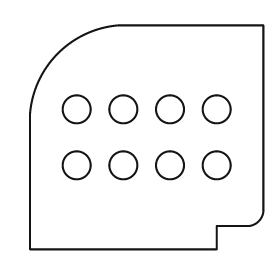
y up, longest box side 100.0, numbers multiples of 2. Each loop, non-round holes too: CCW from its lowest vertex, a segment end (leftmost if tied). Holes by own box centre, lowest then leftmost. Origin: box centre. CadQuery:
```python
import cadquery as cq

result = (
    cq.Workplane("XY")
    .moveTo(-50.0, -48.0)
    .lineTo(30.0, -48.0)
    .lineTo(30.0, -38.0)
    .lineTo(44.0, -38.0)
    .threePointArc((48.0, -36.0), (50.0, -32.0))
    .lineTo(50.0, 48.0)
    .lineTo(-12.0, 48.0)
    .threePointArc((-38.0, 36.0), (-50.0, 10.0))
    .close()
    .moveTo(-30.0, -12.0)
    .circle(6.0)
    .moveTo(-10.0, -12.0)
    .circle(6.0)
    .moveTo(10.0, -12.0)
    .circle(6.0)
    .moveTo(30.0, -12.0)
    .circle(6.0)
    .moveTo(-30.0, 12.0)
    .circle(6.0)
    .moveTo(-10.0, 12.0)
    .circle(6.0)
    .moveTo(10.0, 12.0)
    .circle(6.0)
    .moveTo(30.0, 12.0)
    .circle(6.0)
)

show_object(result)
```